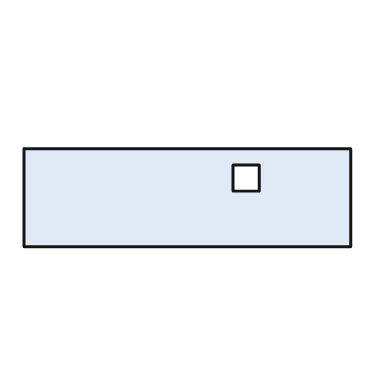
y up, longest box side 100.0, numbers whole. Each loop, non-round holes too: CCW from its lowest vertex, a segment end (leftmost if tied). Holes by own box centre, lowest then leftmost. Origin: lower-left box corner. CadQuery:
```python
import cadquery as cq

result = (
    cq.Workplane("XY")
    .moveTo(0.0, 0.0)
    .lineTo(100.0, 0.0)
    .lineTo(100.0, 30.0)
    .lineTo(0.0, 30.0)
    .close()
    .moveTo(64.0, 17.0)
    .lineTo(72.0, 17.0)
    .lineTo(72.0, 25.0)
    .lineTo(64.0, 25.0)
    .close()
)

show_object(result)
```